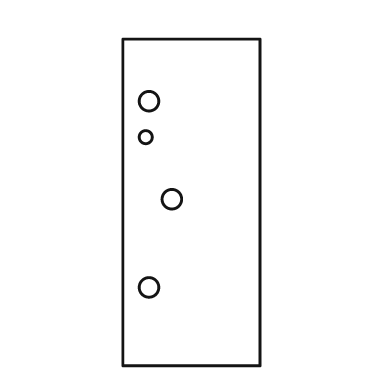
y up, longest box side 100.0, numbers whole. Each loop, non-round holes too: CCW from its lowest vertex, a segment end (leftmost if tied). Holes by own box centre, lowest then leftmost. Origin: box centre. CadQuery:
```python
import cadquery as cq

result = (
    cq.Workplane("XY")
    .moveTo(-21.0, -50.0)
    .lineTo(21.0, -50.0)
    .lineTo(21.0, 50.0)
    .lineTo(-21.0, 50.0)
    .close()
    .moveTo(-13.0, -26.0)
    .circle(3.0)
    .moveTo(-6.0, 1.0)
    .circle(3.0)
    .moveTo(-14.0, 20.0)
    .circle(2.0)
    .moveTo(-13.0, 31.0)
    .circle(3.0)
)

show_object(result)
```